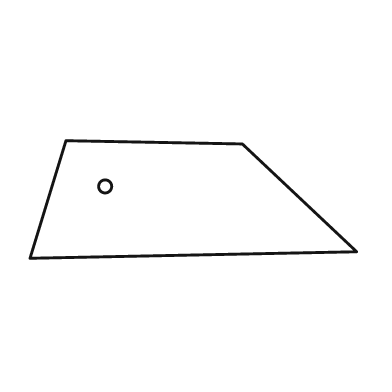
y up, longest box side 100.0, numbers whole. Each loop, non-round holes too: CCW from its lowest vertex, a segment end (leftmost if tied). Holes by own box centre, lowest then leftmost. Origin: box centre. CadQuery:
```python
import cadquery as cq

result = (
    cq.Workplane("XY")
    .moveTo(-50.0, -18.0)
    .lineTo(50.0, -16.0)
    .lineTo(15.0, 17.0)
    .lineTo(-39.0, 18.0)
    .close()
    .moveTo(-27.0, 4.0)
    .circle(2.0)
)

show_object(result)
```